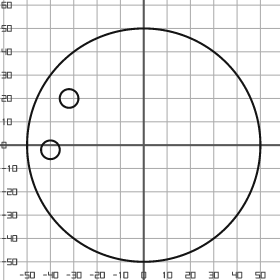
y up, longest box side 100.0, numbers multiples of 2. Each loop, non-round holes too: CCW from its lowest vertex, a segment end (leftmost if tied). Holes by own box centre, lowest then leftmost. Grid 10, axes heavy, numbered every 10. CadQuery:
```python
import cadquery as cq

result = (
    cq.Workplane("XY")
    .moveTo(0.0, 0.0)
    .circle(50.0)
    .moveTo(-40.0, -2.0)
    .circle(4.0)
    .moveTo(-32.0, 20.0)
    .circle(4.0)
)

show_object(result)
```